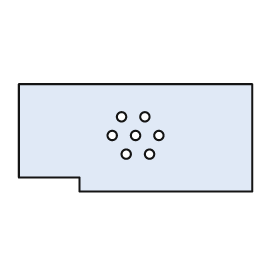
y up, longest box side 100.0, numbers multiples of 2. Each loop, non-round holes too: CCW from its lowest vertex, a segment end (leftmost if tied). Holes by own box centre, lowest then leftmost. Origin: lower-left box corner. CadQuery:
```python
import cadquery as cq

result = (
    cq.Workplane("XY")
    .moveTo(26.0, 0.0)
    .lineTo(100.0, 0.0)
    .lineTo(100.0, 46.0)
    .lineTo(0.0, 46.0)
    .lineTo(0.0, 6.0)
    .lineTo(26.0, 6.0)
    .close()
    .moveTo(46.0, 16.0)
    .circle(2.0)
    .moveTo(56.0, 16.0)
    .circle(2.0)
    .moveTo(40.0, 24.0)
    .circle(2.0)
    .moveTo(50.0, 24.0)
    .circle(2.0)
    .moveTo(60.0, 24.0)
    .circle(2.0)
    .moveTo(44.0, 32.0)
    .circle(2.0)
    .moveTo(54.0, 32.0)
    .circle(2.0)
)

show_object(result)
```